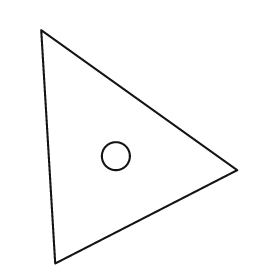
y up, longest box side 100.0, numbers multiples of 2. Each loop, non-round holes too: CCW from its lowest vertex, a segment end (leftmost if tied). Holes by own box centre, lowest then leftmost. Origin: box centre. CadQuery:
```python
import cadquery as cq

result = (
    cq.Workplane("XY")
    .moveTo(-36.0, -50.0)
    .lineTo(42.0, -10.0)
    .lineTo(-42.0, 50.0)
    .close()
    .moveTo(-10.0, -4.0)
    .circle(6.0)
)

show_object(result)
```